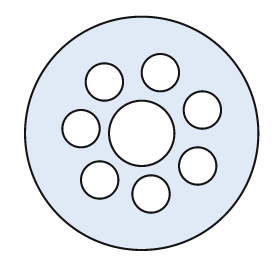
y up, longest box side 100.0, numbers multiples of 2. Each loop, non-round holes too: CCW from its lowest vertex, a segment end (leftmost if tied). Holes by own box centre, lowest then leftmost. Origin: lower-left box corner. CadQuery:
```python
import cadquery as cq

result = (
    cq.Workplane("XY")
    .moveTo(50.0, 50.0)
    .circle(50.0)
    .moveTo(54.0, 24.0)
    .circle(8.0)
    .moveTo(32.0, 30.0)
    .circle(8.0)
    .moveTo(74.0, 36.0)
    .circle(8.0)
    .moveTo(50.0, 50.0)
    .circle(14.0)
    .moveTo(24.0, 52.0)
    .circle(8.0)
    .moveTo(76.0, 60.0)
    .circle(8.0)
    .moveTo(34.0, 72.0)
    .circle(8.0)
    .moveTo(58.0, 76.0)
    .circle(8.0)
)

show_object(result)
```